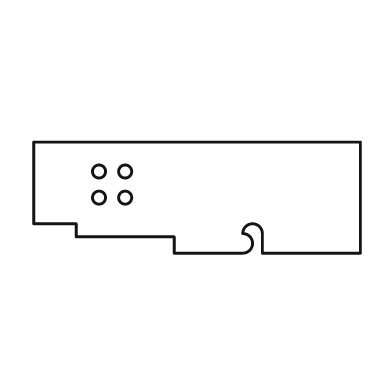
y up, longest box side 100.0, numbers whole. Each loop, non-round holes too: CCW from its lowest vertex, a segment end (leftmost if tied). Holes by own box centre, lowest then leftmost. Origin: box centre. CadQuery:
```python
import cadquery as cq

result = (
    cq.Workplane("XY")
    .moveTo(-7.0, -17.0)
    .lineTo(14.0, -17.0)
    .threePointArc((17.0, -14.0), (14.0, -11.0))
    .threePointArc((17.0, -8.0), (20.0, -11.0))
    .lineTo(20.0, -17.0)
    .lineTo(50.0, -17.0)
    .lineTo(50.0, 17.0)
    .lineTo(-50.0, 17.0)
    .lineTo(-50.0, -8.0)
    .lineTo(-37.0, -8.0)
    .lineTo(-37.0, -12.0)
    .lineTo(-7.0, -12.0)
    .close()
    .moveTo(-30.0, 0.0)
    .circle(2.0)
    .moveTo(-22.0, 0.0)
    .circle(2.0)
    .moveTo(-30.0, 8.0)
    .circle(2.0)
    .moveTo(-22.0, 8.0)
    .circle(2.0)
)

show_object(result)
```